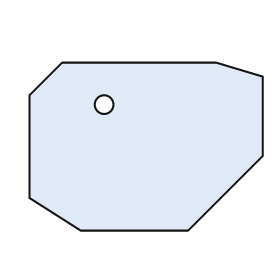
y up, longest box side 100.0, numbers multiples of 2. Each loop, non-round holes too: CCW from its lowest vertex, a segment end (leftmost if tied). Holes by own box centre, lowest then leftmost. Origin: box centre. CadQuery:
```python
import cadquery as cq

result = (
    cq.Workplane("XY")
    .moveTo(-28.0, -36.0)
    .lineTo(18.0, -36.0)
    .lineTo(50.0, -4.0)
    .lineTo(50.0, 30.0)
    .lineTo(30.0, 36.0)
    .lineTo(-36.0, 36.0)
    .lineTo(-50.0, 22.0)
    .lineTo(-50.0, -22.0)
    .close()
    .moveTo(-18.0, 18.0)
    .circle(4.0)
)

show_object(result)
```